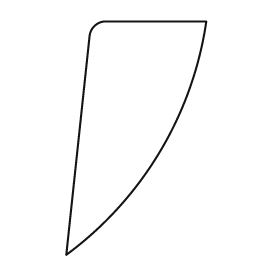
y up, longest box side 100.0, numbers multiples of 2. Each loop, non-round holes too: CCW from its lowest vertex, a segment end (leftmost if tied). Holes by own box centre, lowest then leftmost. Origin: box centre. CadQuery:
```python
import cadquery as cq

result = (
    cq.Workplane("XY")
    .moveTo(-30.0, -50.0)
    .threePointArc((10.0, -6.0), (30.0, 50.0))
    .lineTo(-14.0, 50.0)
    .threePointArc((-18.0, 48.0), (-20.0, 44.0))
    .close()
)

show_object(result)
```